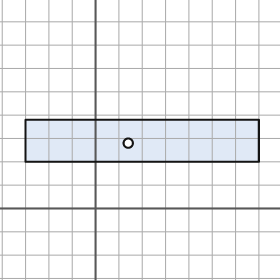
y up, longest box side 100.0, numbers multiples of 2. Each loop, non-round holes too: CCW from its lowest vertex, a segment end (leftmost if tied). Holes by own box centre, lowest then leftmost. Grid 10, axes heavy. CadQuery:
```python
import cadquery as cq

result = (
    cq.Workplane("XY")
    .moveTo(-30.0, 20.0)
    .lineTo(70.0, 20.0)
    .lineTo(70.0, 38.0)
    .lineTo(-30.0, 38.0)
    .close()
    .moveTo(14.0, 28.0)
    .circle(2.0)
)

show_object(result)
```